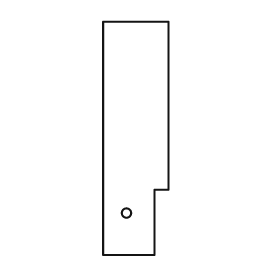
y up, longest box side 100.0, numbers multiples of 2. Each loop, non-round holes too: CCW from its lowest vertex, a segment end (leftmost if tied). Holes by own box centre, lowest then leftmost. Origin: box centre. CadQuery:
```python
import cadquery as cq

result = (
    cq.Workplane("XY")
    .moveTo(-14.0, -50.0)
    .lineTo(8.0, -50.0)
    .lineTo(8.0, -22.0)
    .lineTo(14.0, -22.0)
    .lineTo(14.0, 50.0)
    .lineTo(-14.0, 50.0)
    .close()
    .moveTo(-4.0, -32.0)
    .circle(2.0)
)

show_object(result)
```